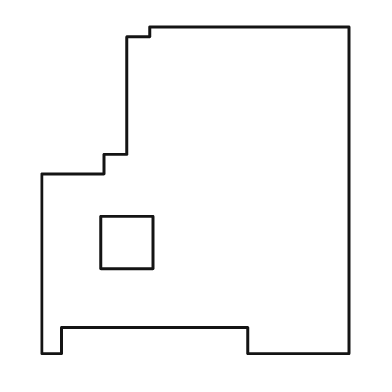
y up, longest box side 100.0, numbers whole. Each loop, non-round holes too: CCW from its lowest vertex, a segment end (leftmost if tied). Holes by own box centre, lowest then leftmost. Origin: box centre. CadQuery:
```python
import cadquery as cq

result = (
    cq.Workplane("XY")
    .moveTo(-47.0, -50.0)
    .lineTo(-41.0, -50.0)
    .lineTo(-41.0, -42.0)
    .lineTo(16.0, -42.0)
    .lineTo(16.0, -50.0)
    .lineTo(47.0, -50.0)
    .lineTo(47.0, 50.0)
    .lineTo(-14.0, 50.0)
    .lineTo(-14.0, 47.0)
    .lineTo(-21.0, 47.0)
    .lineTo(-21.0, 11.0)
    .lineTo(-28.0, 11.0)
    .lineTo(-28.0, 5.0)
    .lineTo(-47.0, 5.0)
    .close()
    .moveTo(-29.0, -24.0)
    .lineTo(-13.0, -24.0)
    .lineTo(-13.0, -8.0)
    .lineTo(-29.0, -8.0)
    .close()
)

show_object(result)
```